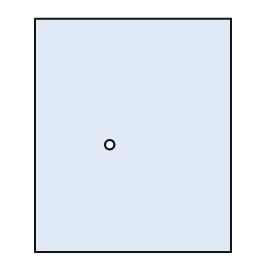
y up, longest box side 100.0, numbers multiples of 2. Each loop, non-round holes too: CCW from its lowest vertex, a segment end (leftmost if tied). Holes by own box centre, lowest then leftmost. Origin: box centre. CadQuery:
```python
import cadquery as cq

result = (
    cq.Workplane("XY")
    .moveTo(-42.0, -50.0)
    .lineTo(42.0, -50.0)
    .lineTo(42.0, 50.0)
    .lineTo(-42.0, 50.0)
    .close()
    .moveTo(-10.0, -4.0)
    .circle(2.0)
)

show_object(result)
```